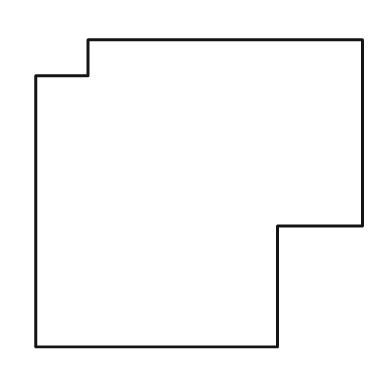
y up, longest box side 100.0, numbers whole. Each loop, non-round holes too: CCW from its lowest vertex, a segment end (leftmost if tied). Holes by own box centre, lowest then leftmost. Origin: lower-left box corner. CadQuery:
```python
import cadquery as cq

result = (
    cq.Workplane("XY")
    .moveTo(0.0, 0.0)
    .lineTo(74.0, 0.0)
    .lineTo(74.0, 37.0)
    .lineTo(100.0, 37.0)
    .lineTo(100.0, 94.0)
    .lineTo(16.0, 94.0)
    .lineTo(16.0, 83.0)
    .lineTo(0.0, 83.0)
    .close()
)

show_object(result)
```